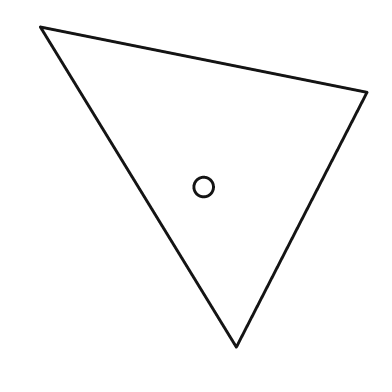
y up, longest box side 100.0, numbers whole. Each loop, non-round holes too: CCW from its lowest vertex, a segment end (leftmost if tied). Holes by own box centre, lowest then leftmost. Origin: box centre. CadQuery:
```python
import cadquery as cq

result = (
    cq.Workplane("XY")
    .moveTo(10.0, -49.0)
    .lineTo(50.0, 29.0)
    .lineTo(-50.0, 49.0)
    .close()
    .moveTo(0.0, 0.0)
    .circle(3.0)
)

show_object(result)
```